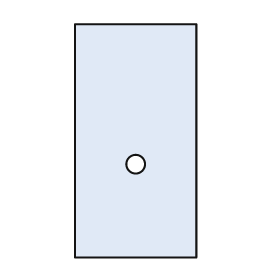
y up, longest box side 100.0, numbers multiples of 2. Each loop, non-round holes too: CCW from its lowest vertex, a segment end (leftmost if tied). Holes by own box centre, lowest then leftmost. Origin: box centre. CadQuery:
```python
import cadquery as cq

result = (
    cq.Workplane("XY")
    .moveTo(-26.0, -50.0)
    .lineTo(26.0, -50.0)
    .lineTo(26.0, 50.0)
    .lineTo(-26.0, 50.0)
    .close()
    .moveTo(0.0, -10.0)
    .circle(4.0)
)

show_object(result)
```